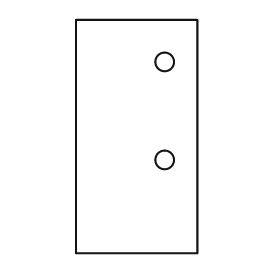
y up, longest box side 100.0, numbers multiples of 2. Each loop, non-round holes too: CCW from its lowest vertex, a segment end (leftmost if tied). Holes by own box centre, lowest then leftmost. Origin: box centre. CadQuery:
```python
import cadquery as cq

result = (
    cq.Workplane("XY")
    .moveTo(-26.0, -50.0)
    .lineTo(26.0, -50.0)
    .lineTo(26.0, 50.0)
    .lineTo(-26.0, 50.0)
    .close()
    .moveTo(12.0, -10.0)
    .circle(4.0)
    .moveTo(12.0, 32.0)
    .circle(4.0)
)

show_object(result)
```